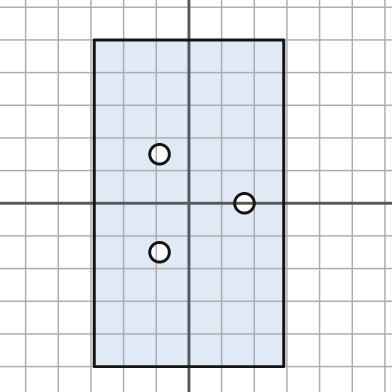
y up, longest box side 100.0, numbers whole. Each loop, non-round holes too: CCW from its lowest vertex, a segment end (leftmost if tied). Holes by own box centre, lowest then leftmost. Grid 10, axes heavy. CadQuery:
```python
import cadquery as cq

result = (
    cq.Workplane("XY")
    .moveTo(-29.0, -50.0)
    .lineTo(29.0, -50.0)
    .lineTo(29.0, 50.0)
    .lineTo(-29.0, 50.0)
    .close()
    .moveTo(-9.0, -15.0)
    .circle(3.0)
    .moveTo(17.0, 0.0)
    .circle(3.0)
    .moveTo(-9.0, 15.0)
    .circle(3.0)
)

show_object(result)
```